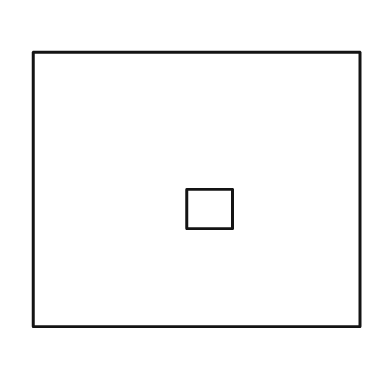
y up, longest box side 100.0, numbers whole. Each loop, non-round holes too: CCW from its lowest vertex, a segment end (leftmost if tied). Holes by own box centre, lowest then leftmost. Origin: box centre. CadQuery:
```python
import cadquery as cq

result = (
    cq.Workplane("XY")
    .moveTo(-50.0, -42.0)
    .lineTo(50.0, -42.0)
    .lineTo(50.0, 42.0)
    .lineTo(-50.0, 42.0)
    .close()
    .moveTo(-3.0, -12.0)
    .lineTo(11.0, -12.0)
    .lineTo(11.0, 0.0)
    .lineTo(-3.0, 0.0)
    .close()
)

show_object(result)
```